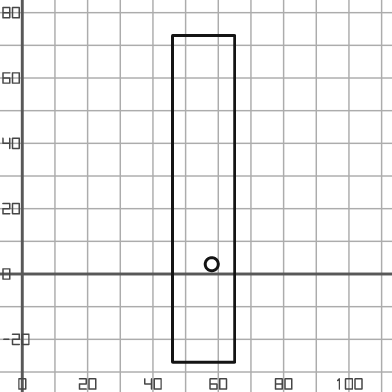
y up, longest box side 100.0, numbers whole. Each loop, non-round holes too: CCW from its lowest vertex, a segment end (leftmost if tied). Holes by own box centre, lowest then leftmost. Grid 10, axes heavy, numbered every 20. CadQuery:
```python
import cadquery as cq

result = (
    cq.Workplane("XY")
    .moveTo(46.0, -27.0)
    .lineTo(65.0, -27.0)
    .lineTo(65.0, 73.0)
    .lineTo(46.0, 73.0)
    .close()
    .moveTo(58.0, 3.0)
    .circle(2.0)
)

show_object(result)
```